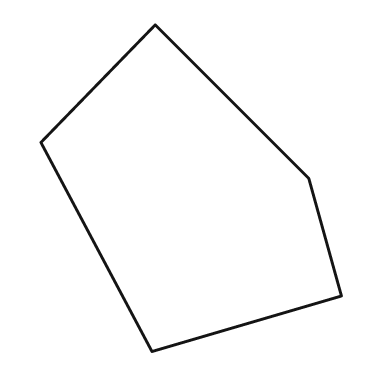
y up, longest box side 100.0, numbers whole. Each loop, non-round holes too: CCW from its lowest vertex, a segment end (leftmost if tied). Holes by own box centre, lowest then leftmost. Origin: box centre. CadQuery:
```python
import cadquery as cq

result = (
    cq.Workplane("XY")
    .moveTo(-12.0, -50.0)
    .lineTo(46.0, -33.0)
    .lineTo(36.0, 3.0)
    .lineTo(-11.0, 50.0)
    .lineTo(-46.0, 14.0)
    .close()
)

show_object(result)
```